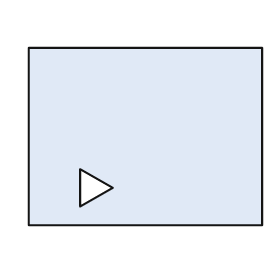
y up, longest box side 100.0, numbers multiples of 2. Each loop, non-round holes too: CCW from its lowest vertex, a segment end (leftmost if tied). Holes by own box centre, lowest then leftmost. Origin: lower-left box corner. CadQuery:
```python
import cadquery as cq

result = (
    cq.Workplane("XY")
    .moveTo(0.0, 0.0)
    .lineTo(100.0, 0.0)
    .lineTo(100.0, 76.0)
    .lineTo(0.0, 76.0)
    .close()
    .moveTo(22.0, 8.0)
    .lineTo(36.0, 16.0)
    .lineTo(22.0, 24.0)
    .close()
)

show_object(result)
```